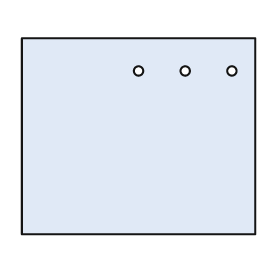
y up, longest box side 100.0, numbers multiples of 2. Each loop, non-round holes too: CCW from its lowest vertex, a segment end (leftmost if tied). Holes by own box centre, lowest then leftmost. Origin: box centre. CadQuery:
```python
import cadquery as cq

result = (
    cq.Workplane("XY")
    .moveTo(-50.0, -42.0)
    .lineTo(50.0, -42.0)
    .lineTo(50.0, 42.0)
    .lineTo(-50.0, 42.0)
    .close()
    .moveTo(0.0, 28.0)
    .circle(2.0)
    .moveTo(20.0, 28.0)
    .circle(2.0)
    .moveTo(40.0, 28.0)
    .circle(2.0)
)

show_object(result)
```